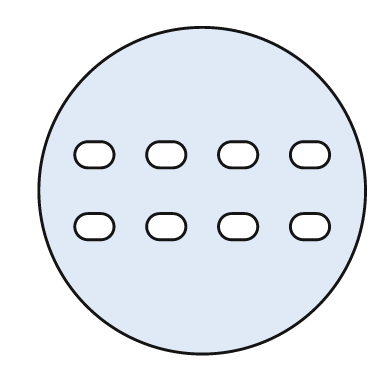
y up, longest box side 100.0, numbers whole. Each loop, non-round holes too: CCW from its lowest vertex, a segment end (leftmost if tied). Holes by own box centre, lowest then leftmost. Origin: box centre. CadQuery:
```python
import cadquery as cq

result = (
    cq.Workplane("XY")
    .moveTo(0.0, 0.0)
    .circle(50.0)
    .moveTo(-35.0, -15.0)
    .lineTo(-31.0, -15.0)
    .threePointArc((-27.0, -11.0), (-31.0, -7.0))
    .lineTo(-35.0, -7.0)
    .threePointArc((-39.0, -11.0), (-35.0, -15.0))
    .close()
    .moveTo(-13.0, -15.0)
    .lineTo(-9.0, -15.0)
    .threePointArc((-5.0, -11.0), (-9.0, -7.0))
    .lineTo(-13.0, -7.0)
    .threePointArc((-17.0, -11.0), (-13.0, -15.0))
    .close()
    .moveTo(9.0, -15.0)
    .lineTo(13.0, -15.0)
    .threePointArc((17.0, -11.0), (13.0, -7.0))
    .lineTo(9.0, -7.0)
    .threePointArc((5.0, -11.0), (9.0, -15.0))
    .close()
    .moveTo(31.0, -15.0)
    .lineTo(35.0, -15.0)
    .threePointArc((39.0, -11.0), (35.0, -7.0))
    .lineTo(31.0, -7.0)
    .threePointArc((27.0, -11.0), (31.0, -15.0))
    .close()
    .moveTo(-35.0, 7.0)
    .lineTo(-31.0, 7.0)
    .threePointArc((-27.0, 11.0), (-31.0, 15.0))
    .lineTo(-35.0, 15.0)
    .threePointArc((-39.0, 11.0), (-35.0, 7.0))
    .close()
    .moveTo(-13.0, 7.0)
    .lineTo(-9.0, 7.0)
    .threePointArc((-5.0, 11.0), (-9.0, 15.0))
    .lineTo(-13.0, 15.0)
    .threePointArc((-17.0, 11.0), (-13.0, 7.0))
    .close()
    .moveTo(9.0, 7.0)
    .lineTo(13.0, 7.0)
    .threePointArc((17.0, 11.0), (13.0, 15.0))
    .lineTo(9.0, 15.0)
    .threePointArc((5.0, 11.0), (9.0, 7.0))
    .close()
    .moveTo(31.0, 7.0)
    .lineTo(35.0, 7.0)
    .threePointArc((39.0, 11.0), (35.0, 15.0))
    .lineTo(31.0, 15.0)
    .threePointArc((27.0, 11.0), (31.0, 7.0))
    .close()
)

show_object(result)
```